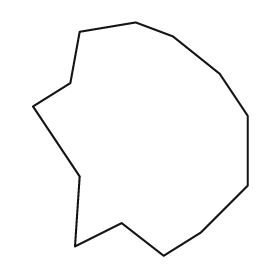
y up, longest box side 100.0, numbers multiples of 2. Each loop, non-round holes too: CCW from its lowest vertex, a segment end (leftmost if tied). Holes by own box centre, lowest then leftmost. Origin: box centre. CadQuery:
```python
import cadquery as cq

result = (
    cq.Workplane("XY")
    .moveTo(10.0, -50.0)
    .lineTo(26.0, -40.0)
    .lineTo(46.0, -20.0)
    .lineTo(46.0, 10.0)
    .lineTo(34.0, 28.0)
    .lineTo(14.0, 44.0)
    .lineTo(-2.0, 50.0)
    .lineTo(-26.0, 46.0)
    .lineTo(-30.0, 24.0)
    .lineTo(-46.0, 14.0)
    .lineTo(-26.0, -16.0)
    .lineTo(-28.0, -46.0)
    .lineTo(-8.0, -36.0)
    .close()
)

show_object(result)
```